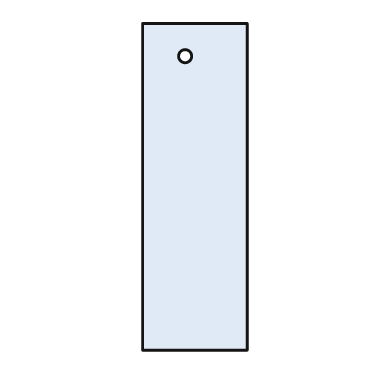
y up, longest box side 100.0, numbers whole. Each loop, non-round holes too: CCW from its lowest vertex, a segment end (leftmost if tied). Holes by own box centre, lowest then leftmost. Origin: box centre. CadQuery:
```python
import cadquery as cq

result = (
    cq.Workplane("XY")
    .moveTo(-16.0, -50.0)
    .lineTo(16.0, -50.0)
    .lineTo(16.0, 50.0)
    .lineTo(-16.0, 50.0)
    .close()
    .moveTo(-3.0, 40.0)
    .circle(2.0)
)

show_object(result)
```